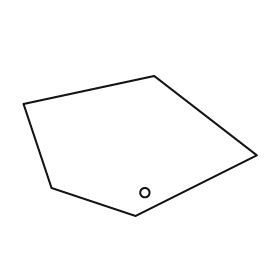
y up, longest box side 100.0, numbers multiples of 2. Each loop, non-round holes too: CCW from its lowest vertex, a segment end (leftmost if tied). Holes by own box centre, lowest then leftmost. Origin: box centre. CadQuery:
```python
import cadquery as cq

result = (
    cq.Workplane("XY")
    .moveTo(-2.0, -30.0)
    .lineTo(50.0, -4.0)
    .lineTo(6.0, 30.0)
    .lineTo(-50.0, 18.0)
    .lineTo(-38.0, -18.0)
    .close()
    .moveTo(2.0, -20.0)
    .circle(2.0)
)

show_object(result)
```